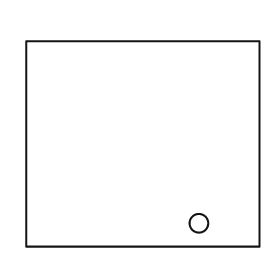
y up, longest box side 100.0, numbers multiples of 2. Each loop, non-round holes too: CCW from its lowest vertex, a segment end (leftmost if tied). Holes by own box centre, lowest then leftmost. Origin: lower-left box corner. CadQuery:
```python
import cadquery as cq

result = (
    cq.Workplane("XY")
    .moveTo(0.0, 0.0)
    .lineTo(100.0, 0.0)
    .lineTo(100.0, 88.0)
    .lineTo(0.0, 88.0)
    .close()
    .moveTo(74.0, 10.0)
    .circle(4.0)
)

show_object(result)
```